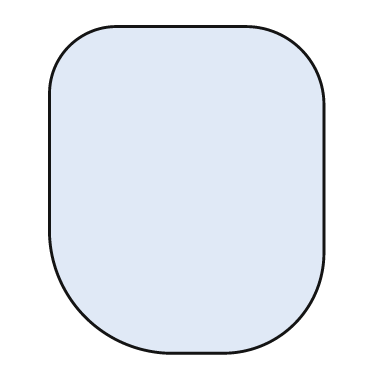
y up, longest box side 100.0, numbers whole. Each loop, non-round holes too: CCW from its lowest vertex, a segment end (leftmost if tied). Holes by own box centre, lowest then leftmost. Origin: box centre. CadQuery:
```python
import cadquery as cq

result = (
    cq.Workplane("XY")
    .moveTo(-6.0, -50.0)
    .lineTo(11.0, -50.0)
    .threePointArc((33.0, -41.0), (42.0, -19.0))
    .lineTo(42.0, 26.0)
    .threePointArc((35.0, 43.0), (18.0, 50.0))
    .lineTo(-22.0, 50.0)
    .threePointArc((-36.0, 44.0), (-42.0, 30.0))
    .lineTo(-42.0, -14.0)
    .threePointArc((-31.0, -39.0), (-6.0, -50.0))
    .close()
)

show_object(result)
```